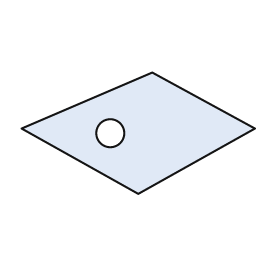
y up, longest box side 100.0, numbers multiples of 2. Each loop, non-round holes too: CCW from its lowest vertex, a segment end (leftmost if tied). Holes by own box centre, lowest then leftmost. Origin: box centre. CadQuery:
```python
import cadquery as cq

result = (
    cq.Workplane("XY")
    .moveTo(0.0, -26.0)
    .lineTo(50.0, 2.0)
    .lineTo(6.0, 26.0)
    .lineTo(-50.0, 2.0)
    .close()
    .moveTo(-12.0, 0.0)
    .circle(6.0)
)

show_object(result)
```